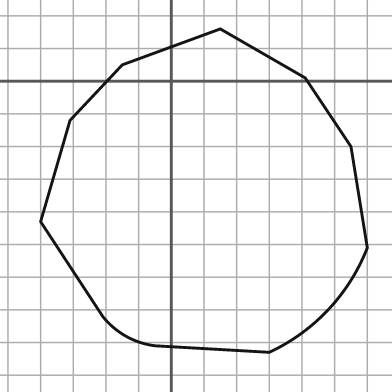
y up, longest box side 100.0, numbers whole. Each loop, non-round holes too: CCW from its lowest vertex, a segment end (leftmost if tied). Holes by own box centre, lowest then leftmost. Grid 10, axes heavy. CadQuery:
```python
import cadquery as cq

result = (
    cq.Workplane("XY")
    .moveTo(30.0, -83.0)
    .threePointArc((48.0, -70.0), (60.0, -51.0))
    .lineTo(55.0, -20.0)
    .lineTo(41.0, 1.0)
    .lineTo(15.0, 16.0)
    .lineTo(-15.0, 5.0)
    .lineTo(-31.0, -12.0)
    .lineTo(-40.0, -43.0)
    .lineTo(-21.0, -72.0)
    .threePointArc((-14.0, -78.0), (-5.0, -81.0))
    .close()
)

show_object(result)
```